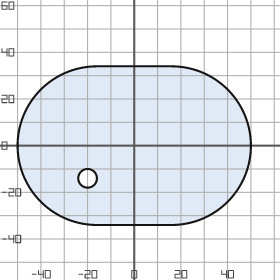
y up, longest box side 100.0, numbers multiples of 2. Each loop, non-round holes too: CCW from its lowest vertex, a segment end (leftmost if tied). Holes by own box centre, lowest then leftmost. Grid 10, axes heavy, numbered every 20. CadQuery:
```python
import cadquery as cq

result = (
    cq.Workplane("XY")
    .moveTo(-16.0, -34.0)
    .lineTo(16.0, -34.0)
    .threePointArc((50.0, 0.0), (16.0, 34.0))
    .lineTo(-16.0, 34.0)
    .threePointArc((-50.0, 0.0), (-16.0, -34.0))
    .close()
    .moveTo(-20.0, -14.0)
    .circle(4.0)
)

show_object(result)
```